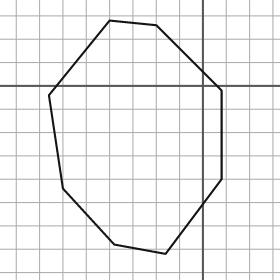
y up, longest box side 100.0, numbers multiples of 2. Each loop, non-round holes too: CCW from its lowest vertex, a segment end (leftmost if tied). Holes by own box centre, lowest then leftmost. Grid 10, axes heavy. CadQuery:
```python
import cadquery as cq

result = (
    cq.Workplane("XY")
    .moveTo(-16.0, -72.0)
    .lineTo(8.0, -40.0)
    .lineTo(8.0, -2.0)
    .lineTo(-20.0, 26.0)
    .lineTo(-40.0, 28.0)
    .lineTo(-66.0, -4.0)
    .lineTo(-60.0, -44.0)
    .lineTo(-38.0, -68.0)
    .close()
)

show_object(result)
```